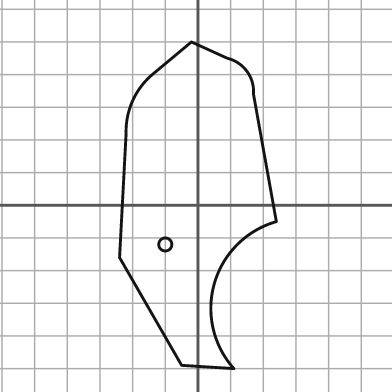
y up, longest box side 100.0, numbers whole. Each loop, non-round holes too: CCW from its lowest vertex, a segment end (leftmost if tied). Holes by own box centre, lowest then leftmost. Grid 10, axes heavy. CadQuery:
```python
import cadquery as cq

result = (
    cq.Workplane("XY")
    .moveTo(11.0, -50.0)
    .threePointArc((5.0, -24.0), (24.0, -5.0))
    .lineTo(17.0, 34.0)
    .threePointArc((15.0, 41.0), (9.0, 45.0))
    .lineTo(-2.0, 50.0)
    .lineTo(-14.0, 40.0)
    .threePointArc((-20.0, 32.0), (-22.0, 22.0))
    .lineTo(-24.0, -16.0)
    .lineTo(-5.0, -49.0)
    .close()
    .moveTo(-10.0, -12.0)
    .circle(2.0)
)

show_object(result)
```